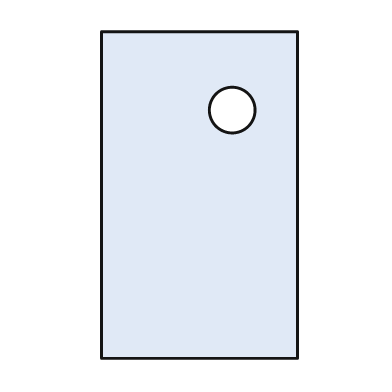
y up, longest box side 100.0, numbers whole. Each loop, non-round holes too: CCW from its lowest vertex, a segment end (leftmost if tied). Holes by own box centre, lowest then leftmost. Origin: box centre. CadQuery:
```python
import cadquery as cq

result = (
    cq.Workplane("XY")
    .moveTo(-30.0, -50.0)
    .lineTo(30.0, -50.0)
    .lineTo(30.0, 50.0)
    .lineTo(-30.0, 50.0)
    .close()
    .moveTo(10.0, 26.0)
    .circle(7.0)
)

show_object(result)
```